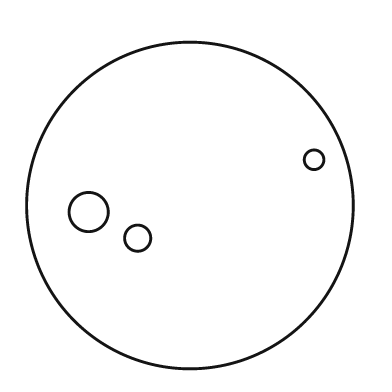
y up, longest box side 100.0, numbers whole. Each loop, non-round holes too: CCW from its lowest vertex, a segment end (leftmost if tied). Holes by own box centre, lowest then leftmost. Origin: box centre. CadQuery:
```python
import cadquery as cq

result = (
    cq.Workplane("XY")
    .moveTo(0.0, 0.0)
    .circle(50.0)
    .moveTo(-16.0, -10.0)
    .circle(4.0)
    .moveTo(-31.0, -2.0)
    .circle(6.0)
    .moveTo(38.0, 14.0)
    .circle(3.0)
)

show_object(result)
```